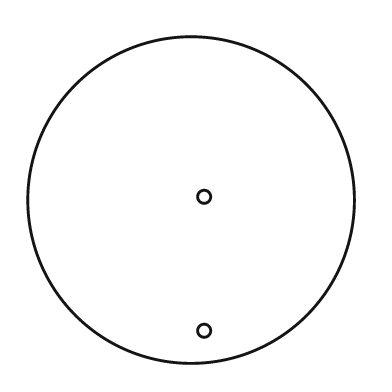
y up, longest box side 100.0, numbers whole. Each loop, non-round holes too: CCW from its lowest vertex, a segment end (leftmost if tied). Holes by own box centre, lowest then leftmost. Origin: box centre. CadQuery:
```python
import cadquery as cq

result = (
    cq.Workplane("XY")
    .moveTo(0.0, 0.0)
    .circle(50.0)
    .moveTo(4.0, -40.0)
    .circle(2.0)
    .moveTo(4.0, 1.0)
    .circle(2.0)
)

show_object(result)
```